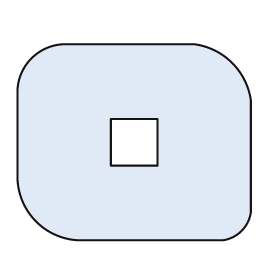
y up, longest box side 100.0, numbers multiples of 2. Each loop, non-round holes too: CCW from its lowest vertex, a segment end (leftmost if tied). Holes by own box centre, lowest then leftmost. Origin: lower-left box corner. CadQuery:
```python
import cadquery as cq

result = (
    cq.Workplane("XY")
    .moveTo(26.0, 0.0)
    .lineTo(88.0, 0.0)
    .threePointArc((96.0, 4.0), (100.0, 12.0))
    .lineTo(100.0, 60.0)
    .threePointArc((92.0, 76.0), (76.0, 84.0))
    .lineTo(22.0, 84.0)
    .threePointArc((6.0, 78.0), (0.0, 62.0))
    .lineTo(0.0, 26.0)
    .threePointArc((8.0, 8.0), (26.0, 0.0))
    .close()
    .moveTo(40.0, 32.0)
    .lineTo(60.0, 32.0)
    .lineTo(60.0, 52.0)
    .lineTo(40.0, 52.0)
    .close()
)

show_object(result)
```